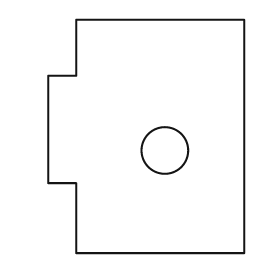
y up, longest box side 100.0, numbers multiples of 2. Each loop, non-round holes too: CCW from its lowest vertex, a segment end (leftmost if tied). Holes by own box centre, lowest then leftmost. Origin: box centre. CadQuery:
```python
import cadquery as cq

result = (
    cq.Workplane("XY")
    .moveTo(-30.0, -50.0)
    .lineTo(42.0, -50.0)
    .lineTo(42.0, 50.0)
    .lineTo(-30.0, 50.0)
    .lineTo(-30.0, 26.0)
    .lineTo(-42.0, 26.0)
    .lineTo(-42.0, -20.0)
    .lineTo(-30.0, -20.0)
    .close()
    .moveTo(8.0, -6.0)
    .circle(10.0)
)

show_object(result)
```